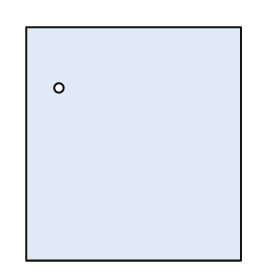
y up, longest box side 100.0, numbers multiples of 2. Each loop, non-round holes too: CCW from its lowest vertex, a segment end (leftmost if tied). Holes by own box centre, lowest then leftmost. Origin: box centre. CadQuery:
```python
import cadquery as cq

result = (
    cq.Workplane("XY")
    .moveTo(-46.0, -50.0)
    .lineTo(46.0, -50.0)
    .lineTo(46.0, 50.0)
    .lineTo(-46.0, 50.0)
    .close()
    .moveTo(-32.0, 24.0)
    .circle(2.0)
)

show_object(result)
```